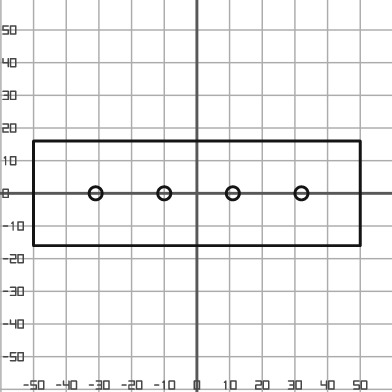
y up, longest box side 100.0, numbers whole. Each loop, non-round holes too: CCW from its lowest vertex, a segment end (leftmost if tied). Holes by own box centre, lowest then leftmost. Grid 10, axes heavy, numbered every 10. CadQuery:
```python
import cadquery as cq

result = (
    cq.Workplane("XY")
    .moveTo(-50.0, -16.0)
    .lineTo(50.0, -16.0)
    .lineTo(50.0, 16.0)
    .lineTo(-50.0, 16.0)
    .close()
    .moveTo(-31.0, 0.0)
    .circle(2.0)
    .moveTo(-10.0, 0.0)
    .circle(2.0)
    .moveTo(11.0, 0.0)
    .circle(2.0)
    .moveTo(32.0, 0.0)
    .circle(2.0)
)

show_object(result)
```